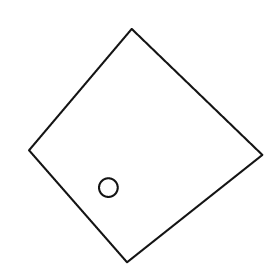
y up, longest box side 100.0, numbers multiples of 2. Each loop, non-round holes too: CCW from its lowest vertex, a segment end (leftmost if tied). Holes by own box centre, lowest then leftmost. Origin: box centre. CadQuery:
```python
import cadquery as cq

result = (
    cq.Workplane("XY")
    .moveTo(-8.0, -50.0)
    .lineTo(50.0, -4.0)
    .lineTo(-6.0, 50.0)
    .lineTo(-50.0, -2.0)
    .close()
    .moveTo(-16.0, -18.0)
    .circle(4.0)
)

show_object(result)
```